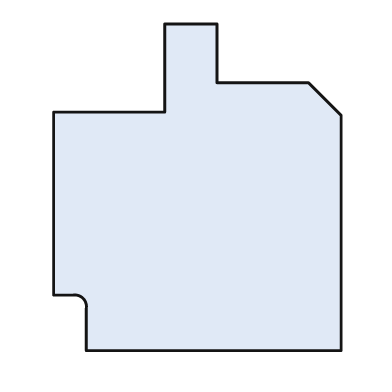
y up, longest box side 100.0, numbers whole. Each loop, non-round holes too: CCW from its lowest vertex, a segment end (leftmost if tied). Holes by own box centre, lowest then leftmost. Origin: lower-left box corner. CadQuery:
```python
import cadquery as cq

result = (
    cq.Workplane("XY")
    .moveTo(10.0, 0.0)
    .lineTo(88.0, 0.0)
    .lineTo(88.0, 72.0)
    .lineTo(78.0, 82.0)
    .lineTo(50.0, 82.0)
    .lineTo(50.0, 100.0)
    .lineTo(34.0, 100.0)
    .lineTo(34.0, 73.0)
    .lineTo(0.0, 73.0)
    .lineTo(0.0, 17.0)
    .lineTo(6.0, 17.0)
    .threePointArc((9.0, 16.0), (10.0, 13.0))
    .close()
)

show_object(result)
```